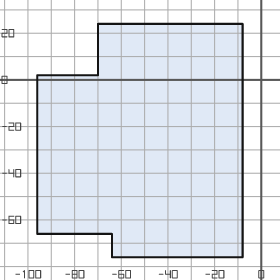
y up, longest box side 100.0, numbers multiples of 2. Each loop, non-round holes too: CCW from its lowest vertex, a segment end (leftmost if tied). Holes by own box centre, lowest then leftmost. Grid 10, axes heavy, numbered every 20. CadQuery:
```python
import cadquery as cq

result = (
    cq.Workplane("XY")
    .moveTo(-64.0, -76.0)
    .lineTo(-8.0, -76.0)
    .lineTo(-8.0, 24.0)
    .lineTo(-70.0, 24.0)
    .lineTo(-70.0, 2.0)
    .lineTo(-96.0, 2.0)
    .lineTo(-96.0, -66.0)
    .lineTo(-64.0, -66.0)
    .close()
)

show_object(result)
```